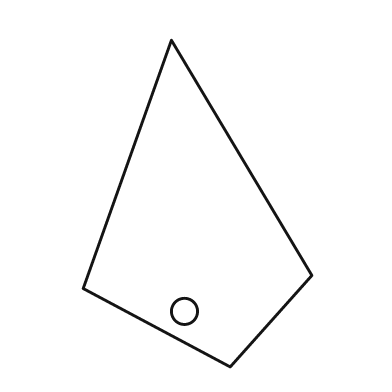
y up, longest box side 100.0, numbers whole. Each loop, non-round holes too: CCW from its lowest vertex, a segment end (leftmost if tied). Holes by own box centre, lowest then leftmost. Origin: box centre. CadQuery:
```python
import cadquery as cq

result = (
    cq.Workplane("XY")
    .moveTo(10.0, -50.0)
    .lineTo(35.0, -22.0)
    .lineTo(-8.0, 50.0)
    .lineTo(-35.0, -26.0)
    .close()
    .moveTo(-4.0, -33.0)
    .circle(4.0)
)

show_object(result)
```